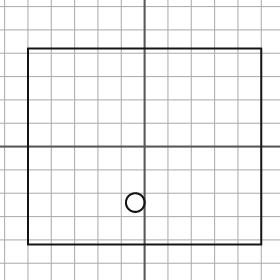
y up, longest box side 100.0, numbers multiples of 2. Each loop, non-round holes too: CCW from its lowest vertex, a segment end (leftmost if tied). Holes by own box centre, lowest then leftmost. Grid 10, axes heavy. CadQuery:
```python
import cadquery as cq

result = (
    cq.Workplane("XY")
    .moveTo(-50.0, -42.0)
    .lineTo(50.0, -42.0)
    .lineTo(50.0, 42.0)
    .lineTo(-50.0, 42.0)
    .close()
    .moveTo(-4.0, -24.0)
    .circle(4.0)
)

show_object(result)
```